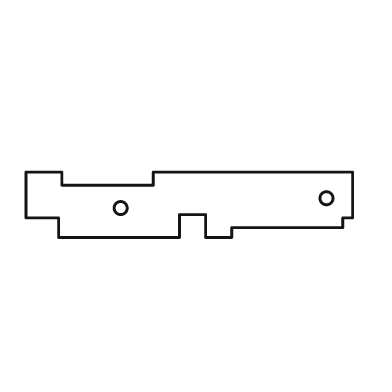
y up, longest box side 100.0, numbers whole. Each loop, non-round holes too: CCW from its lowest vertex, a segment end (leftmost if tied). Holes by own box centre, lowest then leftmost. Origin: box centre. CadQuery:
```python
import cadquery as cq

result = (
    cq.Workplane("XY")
    .moveTo(-40.0, -10.0)
    .lineTo(-3.0, -10.0)
    .lineTo(-3.0, -3.0)
    .lineTo(5.0, -3.0)
    .lineTo(5.0, -10.0)
    .lineTo(13.0, -10.0)
    .lineTo(13.0, -7.0)
    .lineTo(47.0, -7.0)
    .lineTo(47.0, -4.0)
    .lineTo(50.0, -4.0)
    .lineTo(50.0, 10.0)
    .lineTo(-11.0, 10.0)
    .lineTo(-11.0, 6.0)
    .lineTo(-39.0, 6.0)
    .lineTo(-39.0, 10.0)
    .lineTo(-50.0, 10.0)
    .lineTo(-50.0, -4.0)
    .lineTo(-40.0, -4.0)
    .close()
    .moveTo(-21.0, -1.0)
    .circle(2.0)
    .moveTo(42.0, 2.0)
    .circle(2.0)
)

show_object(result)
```